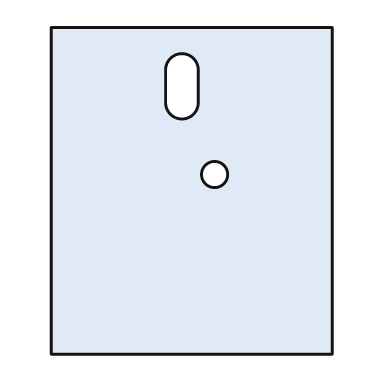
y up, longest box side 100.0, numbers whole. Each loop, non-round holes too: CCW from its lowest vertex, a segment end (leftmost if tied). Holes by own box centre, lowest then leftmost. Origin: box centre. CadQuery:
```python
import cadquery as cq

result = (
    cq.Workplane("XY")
    .moveTo(-43.0, -50.0)
    .lineTo(43.0, -50.0)
    .lineTo(43.0, 50.0)
    .lineTo(-43.0, 50.0)
    .close()
    .moveTo(7.0, 5.0)
    .circle(4.0)
    .moveTo(-8.0, 27.0)
    .threePointArc((-3.0, 22.0), (2.0, 27.0))
    .lineTo(2.0, 37.0)
    .threePointArc((-3.0, 42.0), (-8.0, 37.0))
    .close()
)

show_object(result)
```